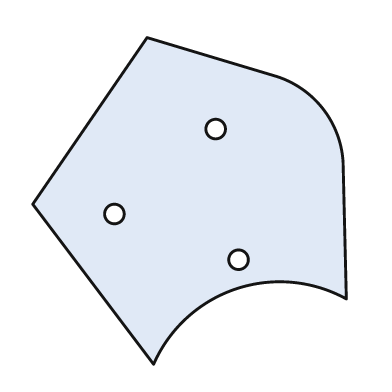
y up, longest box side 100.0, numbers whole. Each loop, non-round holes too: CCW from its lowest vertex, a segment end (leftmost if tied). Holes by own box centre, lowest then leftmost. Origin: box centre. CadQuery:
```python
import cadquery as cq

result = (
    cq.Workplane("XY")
    .moveTo(-11.0, -50.0)
    .threePointArc((14.0, -27.0), (48.0, -30.0))
    .lineTo(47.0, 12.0)
    .threePointArc((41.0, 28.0), (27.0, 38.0))
    .lineTo(-13.0, 50.0)
    .lineTo(-48.0, -1.0)
    .close()
    .moveTo(15.0, -18.0)
    .circle(3.0)
    .moveTo(-23.0, -4.0)
    .circle(3.0)
    .moveTo(8.0, 22.0)
    .circle(3.0)
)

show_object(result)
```